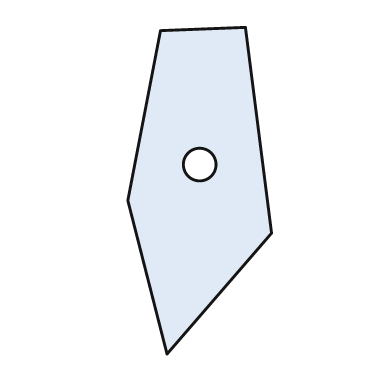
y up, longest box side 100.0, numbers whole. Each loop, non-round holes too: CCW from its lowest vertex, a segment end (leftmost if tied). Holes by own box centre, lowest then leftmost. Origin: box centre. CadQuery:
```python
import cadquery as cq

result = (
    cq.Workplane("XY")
    .moveTo(-10.0, -50.0)
    .lineTo(22.0, -13.0)
    .lineTo(14.0, 50.0)
    .lineTo(-12.0, 49.0)
    .lineTo(-22.0, -3.0)
    .close()
    .moveTo(0.0, 8.0)
    .circle(5.0)
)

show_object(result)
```